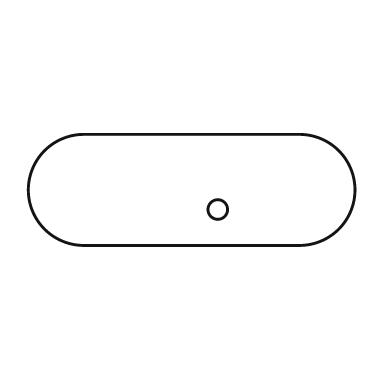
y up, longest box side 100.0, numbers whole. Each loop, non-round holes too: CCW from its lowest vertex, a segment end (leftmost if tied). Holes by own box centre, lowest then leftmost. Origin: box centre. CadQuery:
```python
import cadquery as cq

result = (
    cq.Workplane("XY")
    .moveTo(-33.0, -17.0)
    .lineTo(33.0, -17.0)
    .threePointArc((50.0, 0.0), (33.0, 17.0))
    .lineTo(-33.0, 17.0)
    .threePointArc((-50.0, 0.0), (-33.0, -17.0))
    .close()
    .moveTo(8.0, -6.0)
    .circle(3.0)
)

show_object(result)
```